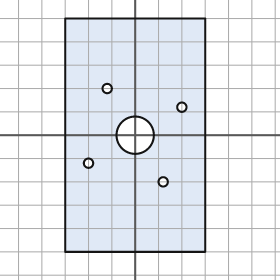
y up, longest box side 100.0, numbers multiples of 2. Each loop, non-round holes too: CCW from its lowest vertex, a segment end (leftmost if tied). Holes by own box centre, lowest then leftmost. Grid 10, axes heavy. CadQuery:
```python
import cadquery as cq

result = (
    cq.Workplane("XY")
    .moveTo(-30.0, -50.0)
    .lineTo(30.0, -50.0)
    .lineTo(30.0, 50.0)
    .lineTo(-30.0, 50.0)
    .close()
    .moveTo(12.0, -20.0)
    .circle(2.0)
    .moveTo(-20.0, -12.0)
    .circle(2.0)
    .moveTo(0.0, 0.0)
    .circle(8.0)
    .moveTo(20.0, 12.0)
    .circle(2.0)
    .moveTo(-12.0, 20.0)
    .circle(2.0)
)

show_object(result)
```